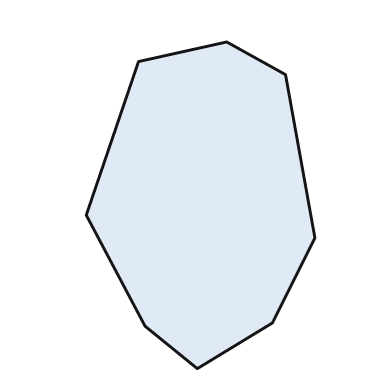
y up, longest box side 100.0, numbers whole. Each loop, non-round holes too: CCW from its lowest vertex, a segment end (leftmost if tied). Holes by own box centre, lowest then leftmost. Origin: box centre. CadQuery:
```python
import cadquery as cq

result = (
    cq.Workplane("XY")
    .moveTo(-1.0, -50.0)
    .lineTo(22.0, -36.0)
    .lineTo(35.0, -10.0)
    .lineTo(26.0, 40.0)
    .lineTo(8.0, 50.0)
    .lineTo(-19.0, 44.0)
    .lineTo(-35.0, -3.0)
    .lineTo(-17.0, -37.0)
    .close()
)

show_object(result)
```